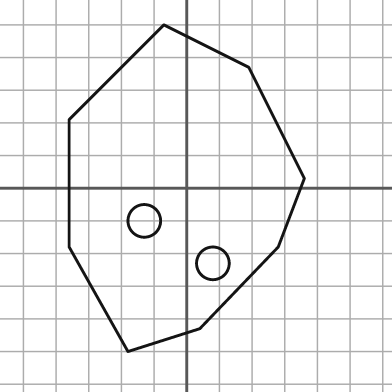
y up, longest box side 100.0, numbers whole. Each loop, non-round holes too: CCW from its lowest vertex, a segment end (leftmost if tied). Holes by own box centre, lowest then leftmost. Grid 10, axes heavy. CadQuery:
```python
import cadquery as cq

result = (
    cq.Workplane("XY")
    .moveTo(-18.0, -50.0)
    .lineTo(4.0, -43.0)
    .lineTo(28.0, -18.0)
    .lineTo(36.0, 3.0)
    .lineTo(19.0, 37.0)
    .lineTo(-7.0, 50.0)
    .lineTo(-36.0, 21.0)
    .lineTo(-36.0, -18.0)
    .close()
    .moveTo(8.0, -23.0)
    .circle(5.0)
    .moveTo(-13.0, -10.0)
    .circle(5.0)
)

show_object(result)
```